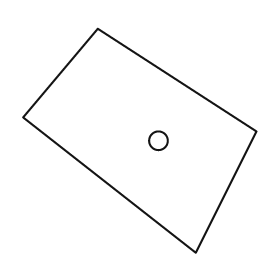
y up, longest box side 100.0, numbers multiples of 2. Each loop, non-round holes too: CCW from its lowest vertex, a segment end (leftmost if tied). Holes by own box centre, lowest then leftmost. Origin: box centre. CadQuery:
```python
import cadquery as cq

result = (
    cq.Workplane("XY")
    .moveTo(24.0, -48.0)
    .lineTo(50.0, 4.0)
    .lineTo(-18.0, 48.0)
    .lineTo(-50.0, 10.0)
    .close()
    .moveTo(8.0, 0.0)
    .circle(4.0)
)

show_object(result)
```